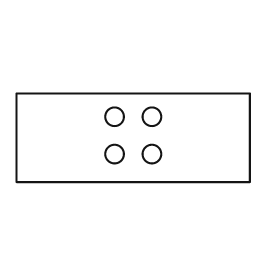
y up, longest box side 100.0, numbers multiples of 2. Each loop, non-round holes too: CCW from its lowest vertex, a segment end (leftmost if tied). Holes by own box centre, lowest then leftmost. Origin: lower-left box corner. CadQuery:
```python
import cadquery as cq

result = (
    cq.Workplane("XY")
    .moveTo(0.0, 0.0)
    .lineTo(100.0, 0.0)
    .lineTo(100.0, 38.0)
    .lineTo(0.0, 38.0)
    .close()
    .moveTo(42.0, 12.0)
    .circle(4.0)
    .moveTo(58.0, 12.0)
    .circle(4.0)
    .moveTo(42.0, 28.0)
    .circle(4.0)
    .moveTo(58.0, 28.0)
    .circle(4.0)
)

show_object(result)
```